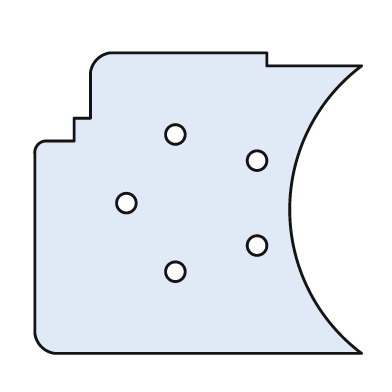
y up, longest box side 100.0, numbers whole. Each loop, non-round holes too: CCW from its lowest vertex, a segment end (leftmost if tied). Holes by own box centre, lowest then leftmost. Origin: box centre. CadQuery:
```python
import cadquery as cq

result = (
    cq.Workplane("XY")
    .moveTo(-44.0, -46.0)
    .lineTo(50.0, -46.0)
    .threePointArc((28.0, -2.0), (50.0, 42.0))
    .lineTo(21.0, 42.0)
    .lineTo(21.0, 46.0)
    .lineTo(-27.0, 46.0)
    .threePointArc((-31.0, 44.0), (-33.0, 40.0))
    .lineTo(-33.0, 26.0)
    .lineTo(-38.0, 26.0)
    .lineTo(-38.0, 19.0)
    .lineTo(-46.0, 19.0)
    .threePointArc((-49.0, 18.0), (-50.0, 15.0))
    .lineTo(-50.0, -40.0)
    .threePointArc((-48.0, -44.0), (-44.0, -46.0))
    .close()
    .moveTo(-7.0, -21.0)
    .circle(3.0)
    .moveTo(18.0, -13.0)
    .circle(3.0)
    .moveTo(-22.0, 0.0)
    .circle(3.0)
    .moveTo(18.0, 13.0)
    .circle(3.0)
    .moveTo(-7.0, 21.0)
    .circle(3.0)
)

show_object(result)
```